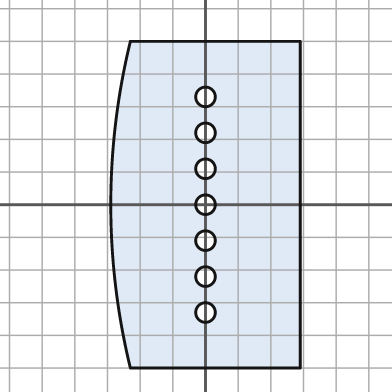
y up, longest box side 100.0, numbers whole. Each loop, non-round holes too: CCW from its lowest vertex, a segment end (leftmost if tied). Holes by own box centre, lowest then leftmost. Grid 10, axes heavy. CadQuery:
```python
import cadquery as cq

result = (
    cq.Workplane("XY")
    .moveTo(-23.0, -50.0)
    .lineTo(29.0, -50.0)
    .lineTo(29.0, 50.0)
    .lineTo(-23.0, 50.0)
    .threePointArc((-29.0, 0.0), (-23.0, -50.0))
    .close()
    .moveTo(0.0, -33.0)
    .circle(3.0)
    .moveTo(0.0, -22.0)
    .circle(3.0)
    .moveTo(0.0, -11.0)
    .circle(3.0)
    .moveTo(0.0, 0.0)
    .circle(3.0)
    .moveTo(0.0, 11.0)
    .circle(3.0)
    .moveTo(0.0, 22.0)
    .circle(3.0)
    .moveTo(0.0, 33.0)
    .circle(3.0)
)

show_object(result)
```